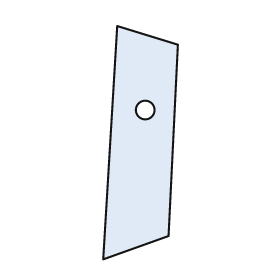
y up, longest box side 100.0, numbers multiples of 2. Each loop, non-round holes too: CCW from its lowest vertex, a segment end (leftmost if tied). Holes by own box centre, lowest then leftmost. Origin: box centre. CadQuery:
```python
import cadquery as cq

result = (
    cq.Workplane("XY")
    .moveTo(-16.0, -50.0)
    .lineTo(12.0, -40.0)
    .lineTo(16.0, 42.0)
    .lineTo(-10.0, 50.0)
    .close()
    .moveTo(2.0, 14.0)
    .circle(4.0)
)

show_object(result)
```